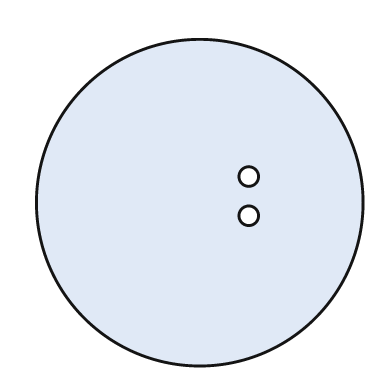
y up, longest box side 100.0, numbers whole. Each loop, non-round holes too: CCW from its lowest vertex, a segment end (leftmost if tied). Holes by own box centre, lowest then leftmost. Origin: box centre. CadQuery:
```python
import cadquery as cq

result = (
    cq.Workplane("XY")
    .moveTo(0.0, 0.0)
    .circle(50.0)
    .moveTo(15.0, -4.0)
    .circle(3.0)
    .moveTo(15.0, 8.0)
    .circle(3.0)
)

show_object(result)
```